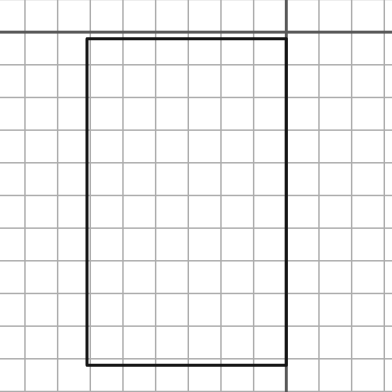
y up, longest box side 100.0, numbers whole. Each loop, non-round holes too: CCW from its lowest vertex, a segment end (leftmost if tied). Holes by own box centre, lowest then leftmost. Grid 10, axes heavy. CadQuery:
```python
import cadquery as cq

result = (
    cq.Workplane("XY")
    .moveTo(-61.0, -102.0)
    .lineTo(0.0, -102.0)
    .lineTo(0.0, -2.0)
    .lineTo(-61.0, -2.0)
    .close()
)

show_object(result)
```